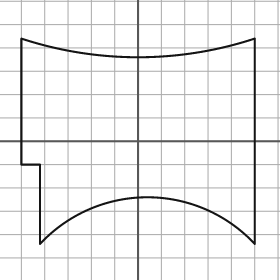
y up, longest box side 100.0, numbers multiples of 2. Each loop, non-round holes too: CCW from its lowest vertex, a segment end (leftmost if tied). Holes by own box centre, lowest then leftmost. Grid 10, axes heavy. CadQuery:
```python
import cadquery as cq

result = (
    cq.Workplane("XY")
    .moveTo(-42.0, -44.0)
    .threePointArc((4.0, -24.0), (50.0, -44.0))
    .lineTo(50.0, 44.0)
    .threePointArc((0.0, 36.0), (-50.0, 44.0))
    .lineTo(-50.0, -10.0)
    .lineTo(-42.0, -10.0)
    .close()
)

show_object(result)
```